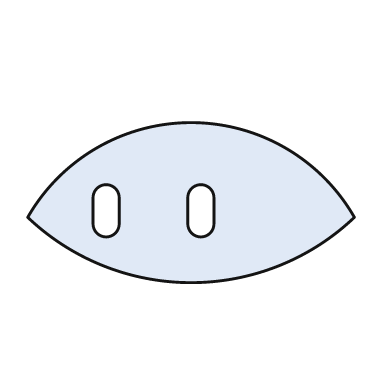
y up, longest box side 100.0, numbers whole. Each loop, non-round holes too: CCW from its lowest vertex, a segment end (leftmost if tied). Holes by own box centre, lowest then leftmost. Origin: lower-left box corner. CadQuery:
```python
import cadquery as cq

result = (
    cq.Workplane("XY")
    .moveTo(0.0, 20.0)
    .threePointArc((50.0, 0.0), (100.0, 20.0))
    .threePointArc((50.0, 49.0), (0.0, 20.0))
    .close()
    .moveTo(20.0, 18.0)
    .threePointArc((24.0, 14.0), (28.0, 18.0))
    .lineTo(28.0, 26.0)
    .threePointArc((24.0, 30.0), (20.0, 26.0))
    .close()
    .moveTo(49.0, 18.0)
    .threePointArc((53.0, 14.0), (57.0, 18.0))
    .lineTo(57.0, 26.0)
    .threePointArc((53.0, 30.0), (49.0, 26.0))
    .close()
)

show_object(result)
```